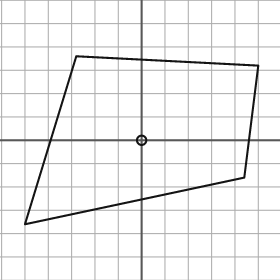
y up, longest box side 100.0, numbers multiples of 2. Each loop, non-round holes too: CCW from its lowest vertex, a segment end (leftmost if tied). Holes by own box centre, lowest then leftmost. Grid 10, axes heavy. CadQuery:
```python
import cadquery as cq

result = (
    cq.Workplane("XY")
    .moveTo(-50.0, -36.0)
    .lineTo(44.0, -16.0)
    .lineTo(50.0, 32.0)
    .lineTo(-28.0, 36.0)
    .close()
    .moveTo(0.0, 0.0)
    .circle(2.0)
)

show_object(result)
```